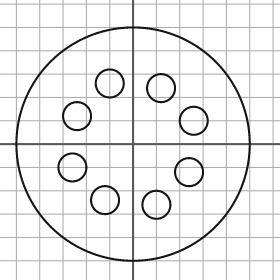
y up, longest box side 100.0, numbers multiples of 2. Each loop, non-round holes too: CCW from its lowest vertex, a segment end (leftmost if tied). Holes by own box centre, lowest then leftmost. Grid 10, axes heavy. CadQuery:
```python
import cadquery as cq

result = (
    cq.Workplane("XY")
    .moveTo(0.0, 0.0)
    .circle(50.0)
    .moveTo(10.0, -26.0)
    .circle(6.0)
    .moveTo(-12.0, -24.0)
    .circle(6.0)
    .moveTo(24.0, -12.0)
    .circle(6.0)
    .moveTo(-26.0, -10.0)
    .circle(6.0)
    .moveTo(26.0, 10.0)
    .circle(6.0)
    .moveTo(-24.0, 12.0)
    .circle(6.0)
    .moveTo(12.0, 24.0)
    .circle(6.0)
    .moveTo(-10.0, 26.0)
    .circle(6.0)
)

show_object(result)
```